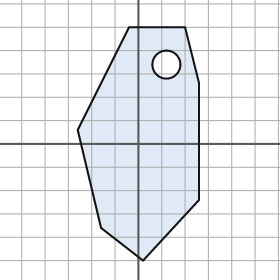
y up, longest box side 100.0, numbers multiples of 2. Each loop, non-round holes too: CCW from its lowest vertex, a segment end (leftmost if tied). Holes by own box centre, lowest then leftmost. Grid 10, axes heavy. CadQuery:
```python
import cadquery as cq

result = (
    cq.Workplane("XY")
    .moveTo(2.0, -50.0)
    .lineTo(26.0, -24.0)
    .lineTo(26.0, 26.0)
    .lineTo(20.0, 50.0)
    .lineTo(-4.0, 50.0)
    .lineTo(-26.0, 6.0)
    .lineTo(-16.0, -36.0)
    .close()
    .moveTo(12.0, 34.0)
    .circle(6.0)
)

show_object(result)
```